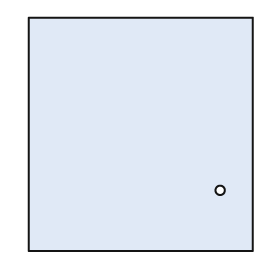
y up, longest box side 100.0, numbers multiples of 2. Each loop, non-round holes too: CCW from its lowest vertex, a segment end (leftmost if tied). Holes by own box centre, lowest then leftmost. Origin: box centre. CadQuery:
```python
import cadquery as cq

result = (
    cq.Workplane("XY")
    .moveTo(-48.0, -50.0)
    .lineTo(48.0, -50.0)
    .lineTo(48.0, 50.0)
    .lineTo(-48.0, 50.0)
    .close()
    .moveTo(34.0, -24.0)
    .circle(2.0)
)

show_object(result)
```